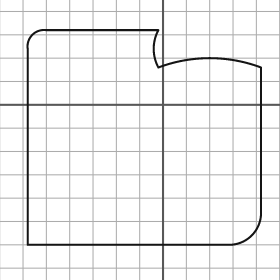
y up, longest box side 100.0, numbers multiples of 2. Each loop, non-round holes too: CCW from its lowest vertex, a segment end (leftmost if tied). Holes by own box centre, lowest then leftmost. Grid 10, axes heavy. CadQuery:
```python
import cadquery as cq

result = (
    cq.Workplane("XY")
    .moveTo(-58.0, -60.0)
    .lineTo(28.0, -60.0)
    .threePointArc((38.0, -56.0), (42.0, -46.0))
    .lineTo(42.0, 16.0)
    .threePointArc((20.0, 20.0), (-2.0, 16.0))
    .threePointArc((-4.0, 24.0), (-2.0, 32.0))
    .lineTo(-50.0, 32.0)
    .threePointArc((-56.0, 30.0), (-58.0, 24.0))
    .close()
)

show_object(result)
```